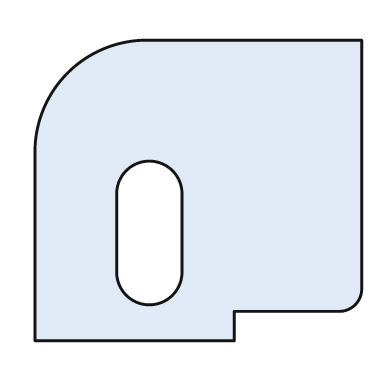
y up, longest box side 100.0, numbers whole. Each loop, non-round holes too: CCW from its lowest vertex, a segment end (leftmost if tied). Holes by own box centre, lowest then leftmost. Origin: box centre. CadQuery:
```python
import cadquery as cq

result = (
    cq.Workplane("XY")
    .moveTo(-50.0, -46.0)
    .lineTo(11.0, -46.0)
    .lineTo(11.0, -37.0)
    .lineTo(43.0, -37.0)
    .threePointArc((48.0, -35.0), (50.0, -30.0))
    .lineTo(50.0, 46.0)
    .lineTo(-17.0, 46.0)
    .threePointArc((-40.0, 36.0), (-50.0, 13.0))
    .close()
    .moveTo(-25.0, -25.0)
    .threePointArc((-15.0, -35.0), (-5.0, -25.0))
    .lineTo(-5.0, -1.0)
    .threePointArc((-15.0, 9.0), (-25.0, -1.0))
    .close()
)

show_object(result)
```